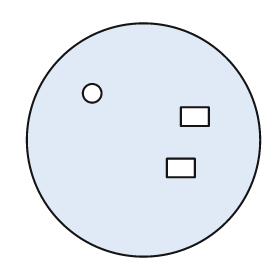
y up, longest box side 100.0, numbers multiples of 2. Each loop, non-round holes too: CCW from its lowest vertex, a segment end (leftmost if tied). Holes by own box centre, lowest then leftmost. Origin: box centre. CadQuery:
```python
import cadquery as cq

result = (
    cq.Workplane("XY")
    .moveTo(0.0, 0.0)
    .circle(50.0)
    .moveTo(10.0, -16.0)
    .lineTo(22.0, -16.0)
    .lineTo(22.0, -8.0)
    .lineTo(10.0, -8.0)
    .close()
    .moveTo(16.0, 6.0)
    .lineTo(28.0, 6.0)
    .lineTo(28.0, 14.0)
    .lineTo(16.0, 14.0)
    .close()
    .moveTo(-22.0, 20.0)
    .circle(4.0)
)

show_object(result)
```